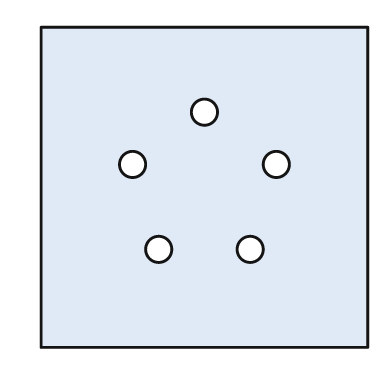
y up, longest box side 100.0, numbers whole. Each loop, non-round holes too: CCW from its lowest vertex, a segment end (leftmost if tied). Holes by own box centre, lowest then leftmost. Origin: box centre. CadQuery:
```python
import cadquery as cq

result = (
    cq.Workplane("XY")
    .moveTo(-50.0, -49.0)
    .lineTo(50.0, -49.0)
    .lineTo(50.0, 49.0)
    .lineTo(-50.0, 49.0)
    .close()
    .moveTo(-14.0, -19.0)
    .circle(4.0)
    .moveTo(14.0, -19.0)
    .circle(4.0)
    .moveTo(-22.0, 7.0)
    .circle(4.0)
    .moveTo(22.0, 7.0)
    .circle(4.0)
    .moveTo(0.0, 23.0)
    .circle(4.0)
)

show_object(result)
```